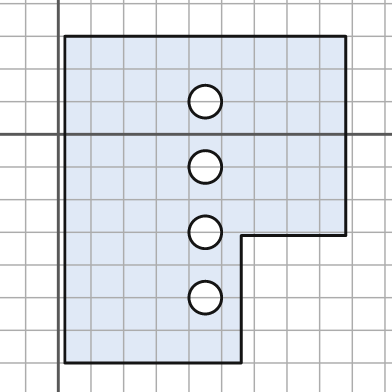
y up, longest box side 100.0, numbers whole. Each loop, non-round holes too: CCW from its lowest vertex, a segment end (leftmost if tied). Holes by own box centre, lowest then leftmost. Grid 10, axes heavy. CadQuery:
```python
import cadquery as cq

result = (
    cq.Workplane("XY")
    .moveTo(2.0, -70.0)
    .lineTo(56.0, -70.0)
    .lineTo(56.0, -31.0)
    .lineTo(88.0, -31.0)
    .lineTo(88.0, 30.0)
    .lineTo(2.0, 30.0)
    .close()
    .moveTo(45.0, -50.0)
    .circle(5.0)
    .moveTo(45.0, -30.0)
    .circle(5.0)
    .moveTo(45.0, -10.0)
    .circle(5.0)
    .moveTo(45.0, 10.0)
    .circle(5.0)
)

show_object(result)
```